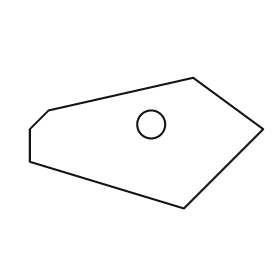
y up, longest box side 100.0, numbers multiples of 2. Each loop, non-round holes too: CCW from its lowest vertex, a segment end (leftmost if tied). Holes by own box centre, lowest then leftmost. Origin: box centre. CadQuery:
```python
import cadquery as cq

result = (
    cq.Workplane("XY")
    .moveTo(16.0, -28.0)
    .lineTo(50.0, 6.0)
    .lineTo(20.0, 28.0)
    .lineTo(-42.0, 14.0)
    .lineTo(-50.0, 6.0)
    .lineTo(-50.0, -8.0)
    .close()
    .moveTo(2.0, 8.0)
    .circle(6.0)
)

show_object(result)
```